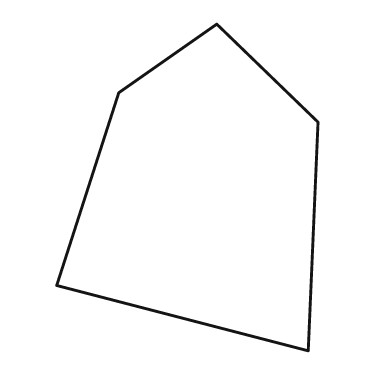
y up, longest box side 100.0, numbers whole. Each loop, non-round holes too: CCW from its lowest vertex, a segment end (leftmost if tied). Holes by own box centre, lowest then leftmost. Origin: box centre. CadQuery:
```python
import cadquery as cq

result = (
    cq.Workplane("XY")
    .moveTo(37.0, -50.0)
    .lineTo(40.0, 20.0)
    .lineTo(9.0, 50.0)
    .lineTo(-21.0, 29.0)
    .lineTo(-40.0, -30.0)
    .close()
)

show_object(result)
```